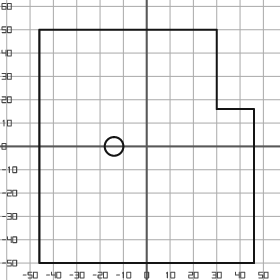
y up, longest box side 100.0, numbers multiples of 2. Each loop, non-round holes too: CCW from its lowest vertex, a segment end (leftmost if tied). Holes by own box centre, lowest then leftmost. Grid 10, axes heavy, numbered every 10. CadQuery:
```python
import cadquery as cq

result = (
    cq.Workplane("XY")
    .moveTo(-46.0, -50.0)
    .lineTo(46.0, -50.0)
    .lineTo(46.0, 16.0)
    .lineTo(30.0, 16.0)
    .lineTo(30.0, 50.0)
    .lineTo(-46.0, 50.0)
    .close()
    .moveTo(-14.0, 0.0)
    .circle(4.0)
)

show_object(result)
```